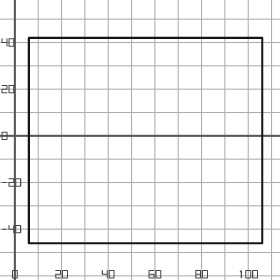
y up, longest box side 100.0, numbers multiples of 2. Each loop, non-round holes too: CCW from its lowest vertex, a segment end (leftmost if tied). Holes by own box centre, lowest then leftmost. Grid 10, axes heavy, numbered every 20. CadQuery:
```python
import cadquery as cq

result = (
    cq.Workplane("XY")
    .moveTo(6.0, -46.0)
    .lineTo(106.0, -46.0)
    .lineTo(106.0, 42.0)
    .lineTo(6.0, 42.0)
    .close()
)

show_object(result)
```